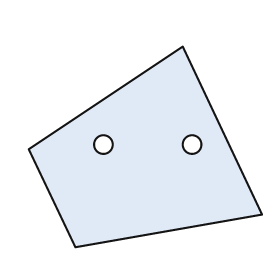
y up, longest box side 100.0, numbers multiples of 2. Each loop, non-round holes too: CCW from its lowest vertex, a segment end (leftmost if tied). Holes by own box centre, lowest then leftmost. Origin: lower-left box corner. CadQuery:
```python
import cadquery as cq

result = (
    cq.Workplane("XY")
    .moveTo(20.0, 0.0)
    .lineTo(100.0, 14.0)
    .lineTo(66.0, 86.0)
    .lineTo(0.0, 42.0)
    .close()
    .moveTo(32.0, 44.0)
    .circle(4.0)
    .moveTo(70.0, 44.0)
    .circle(4.0)
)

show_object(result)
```